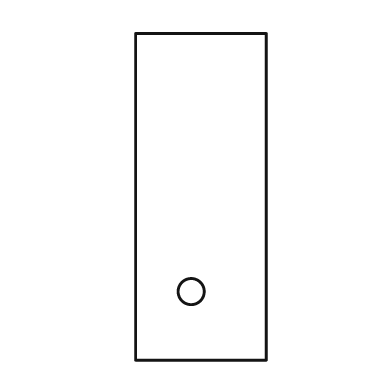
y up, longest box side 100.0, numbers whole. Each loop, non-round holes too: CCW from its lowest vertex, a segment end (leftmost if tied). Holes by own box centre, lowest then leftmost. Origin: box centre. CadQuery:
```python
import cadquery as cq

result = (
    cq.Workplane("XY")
    .moveTo(-20.0, -50.0)
    .lineTo(20.0, -50.0)
    .lineTo(20.0, 50.0)
    .lineTo(-20.0, 50.0)
    .close()
    .moveTo(-3.0, -29.0)
    .circle(4.0)
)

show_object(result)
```